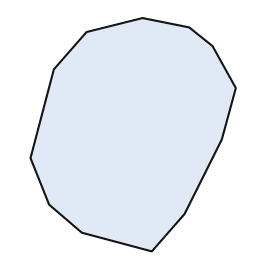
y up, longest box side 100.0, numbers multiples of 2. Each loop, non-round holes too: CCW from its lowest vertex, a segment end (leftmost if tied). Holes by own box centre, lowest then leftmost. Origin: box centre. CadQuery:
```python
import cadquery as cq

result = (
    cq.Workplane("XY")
    .moveTo(8.0, -50.0)
    .lineTo(22.0, -34.0)
    .lineTo(38.0, -2.0)
    .lineTo(44.0, 20.0)
    .lineTo(34.0, 38.0)
    .lineTo(24.0, 46.0)
    .lineTo(4.0, 50.0)
    .lineTo(-20.0, 44.0)
    .lineTo(-34.0, 28.0)
    .lineTo(-44.0, -10.0)
    .lineTo(-36.0, -30.0)
    .lineTo(-22.0, -42.0)
    .close()
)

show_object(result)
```